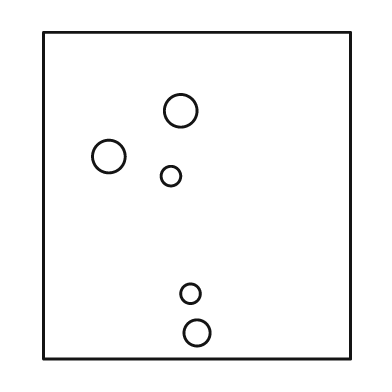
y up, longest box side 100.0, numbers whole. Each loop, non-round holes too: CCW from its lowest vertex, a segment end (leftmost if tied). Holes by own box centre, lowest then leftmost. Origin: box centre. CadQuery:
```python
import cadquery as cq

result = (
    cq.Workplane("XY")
    .moveTo(-47.0, -50.0)
    .lineTo(47.0, -50.0)
    .lineTo(47.0, 50.0)
    .lineTo(-47.0, 50.0)
    .close()
    .moveTo(0.0, -42.0)
    .circle(4.0)
    .moveTo(-2.0, -30.0)
    .circle(3.0)
    .moveTo(-8.0, 6.0)
    .circle(3.0)
    .moveTo(-27.0, 12.0)
    .circle(5.0)
    .moveTo(-5.0, 26.0)
    .circle(5.0)
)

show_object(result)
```